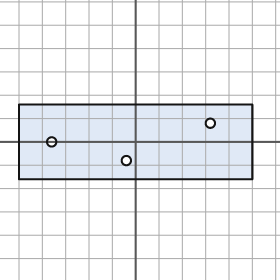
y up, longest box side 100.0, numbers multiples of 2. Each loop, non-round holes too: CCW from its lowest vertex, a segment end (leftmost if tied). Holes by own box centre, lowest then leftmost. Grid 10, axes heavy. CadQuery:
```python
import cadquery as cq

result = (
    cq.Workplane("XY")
    .moveTo(-50.0, -16.0)
    .lineTo(50.0, -16.0)
    .lineTo(50.0, 16.0)
    .lineTo(-50.0, 16.0)
    .close()
    .moveTo(-4.0, -8.0)
    .circle(2.0)
    .moveTo(-36.0, 0.0)
    .circle(2.0)
    .moveTo(32.0, 8.0)
    .circle(2.0)
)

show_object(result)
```